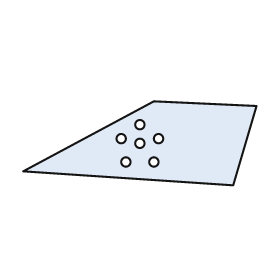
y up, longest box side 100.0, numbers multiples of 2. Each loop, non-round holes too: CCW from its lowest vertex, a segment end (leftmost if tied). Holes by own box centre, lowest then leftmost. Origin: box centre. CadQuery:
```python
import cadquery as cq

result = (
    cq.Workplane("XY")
    .moveTo(40.0, -18.0)
    .lineTo(50.0, 16.0)
    .lineTo(6.0, 18.0)
    .lineTo(-50.0, -12.0)
    .close()
    .moveTo(-6.0, -8.0)
    .circle(2.0)
    .moveTo(6.0, -8.0)
    .circle(2.0)
    .moveTo(0.0, 0.0)
    .circle(2.0)
    .moveTo(-8.0, 2.0)
    .circle(2.0)
    .moveTo(8.0, 2.0)
    .circle(2.0)
    .moveTo(0.0, 8.0)
    .circle(2.0)
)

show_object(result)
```